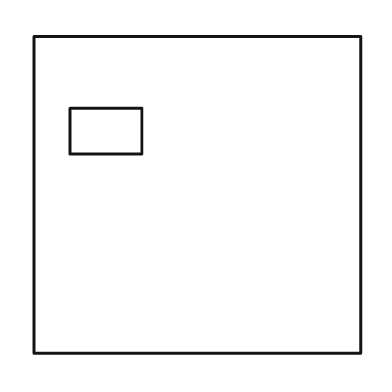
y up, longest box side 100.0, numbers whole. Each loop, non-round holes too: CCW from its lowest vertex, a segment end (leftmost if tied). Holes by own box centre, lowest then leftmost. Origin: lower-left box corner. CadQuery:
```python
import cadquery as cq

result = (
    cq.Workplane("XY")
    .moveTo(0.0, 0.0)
    .lineTo(100.0, 0.0)
    .lineTo(100.0, 97.0)
    .lineTo(0.0, 97.0)
    .close()
    .moveTo(11.0, 61.0)
    .lineTo(33.0, 61.0)
    .lineTo(33.0, 75.0)
    .lineTo(11.0, 75.0)
    .close()
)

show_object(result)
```